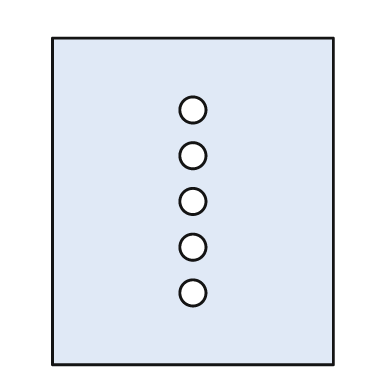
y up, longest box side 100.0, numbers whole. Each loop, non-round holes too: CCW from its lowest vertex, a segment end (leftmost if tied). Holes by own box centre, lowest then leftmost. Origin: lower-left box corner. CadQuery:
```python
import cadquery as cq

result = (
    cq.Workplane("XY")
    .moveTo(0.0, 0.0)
    .lineTo(86.0, 0.0)
    .lineTo(86.0, 100.0)
    .lineTo(0.0, 100.0)
    .close()
    .moveTo(43.0, 22.0)
    .circle(4.0)
    .moveTo(43.0, 36.0)
    .circle(4.0)
    .moveTo(43.0, 50.0)
    .circle(4.0)
    .moveTo(43.0, 64.0)
    .circle(4.0)
    .moveTo(43.0, 78.0)
    .circle(4.0)
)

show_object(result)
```